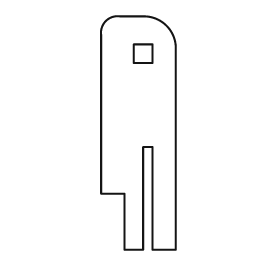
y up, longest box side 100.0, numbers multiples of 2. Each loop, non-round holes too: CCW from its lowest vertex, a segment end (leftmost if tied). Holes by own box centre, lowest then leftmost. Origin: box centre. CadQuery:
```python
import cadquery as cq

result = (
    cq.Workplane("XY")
    .moveTo(-6.0, -50.0)
    .lineTo(2.0, -50.0)
    .lineTo(2.0, -6.0)
    .lineTo(6.0, -6.0)
    .lineTo(6.0, -50.0)
    .lineTo(16.0, -50.0)
    .lineTo(16.0, 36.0)
    .threePointArc((12.0, 46.0), (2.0, 50.0))
    .lineTo(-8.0, 50.0)
    .threePointArc((-14.0, 48.0), (-16.0, 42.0))
    .lineTo(-16.0, -26.0)
    .lineTo(-6.0, -26.0)
    .close()
    .moveTo(-2.0, 30.0)
    .lineTo(6.0, 30.0)
    .lineTo(6.0, 38.0)
    .lineTo(-2.0, 38.0)
    .close()
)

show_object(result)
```